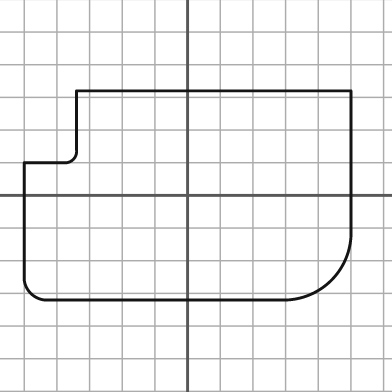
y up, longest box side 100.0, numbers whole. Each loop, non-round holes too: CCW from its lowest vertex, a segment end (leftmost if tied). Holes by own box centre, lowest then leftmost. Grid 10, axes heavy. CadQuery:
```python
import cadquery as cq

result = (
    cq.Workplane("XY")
    .moveTo(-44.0, -32.0)
    .lineTo(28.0, -32.0)
    .threePointArc((44.0, -26.0), (50.0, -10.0))
    .lineTo(50.0, 32.0)
    .lineTo(-34.0, 32.0)
    .lineTo(-34.0, 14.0)
    .threePointArc((-35.0, 11.0), (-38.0, 10.0))
    .lineTo(-50.0, 10.0)
    .lineTo(-50.0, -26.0)
    .threePointArc((-48.0, -30.0), (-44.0, -32.0))
    .close()
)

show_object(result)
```